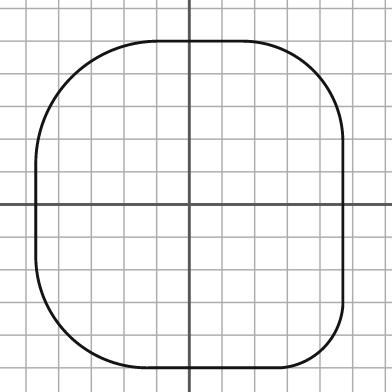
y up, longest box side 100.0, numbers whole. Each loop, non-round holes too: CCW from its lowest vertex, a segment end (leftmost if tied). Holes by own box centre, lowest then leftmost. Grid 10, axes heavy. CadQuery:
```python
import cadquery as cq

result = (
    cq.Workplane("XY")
    .moveTo(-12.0, -50.0)
    .lineTo(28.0, -50.0)
    .threePointArc((41.0, -44.0), (47.0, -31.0))
    .lineTo(47.0, 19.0)
    .threePointArc((38.0, 41.0), (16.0, 50.0))
    .lineTo(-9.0, 50.0)
    .threePointArc((-36.0, 39.0), (-47.0, 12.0))
    .lineTo(-47.0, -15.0)
    .threePointArc((-37.0, -40.0), (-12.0, -50.0))
    .close()
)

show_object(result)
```